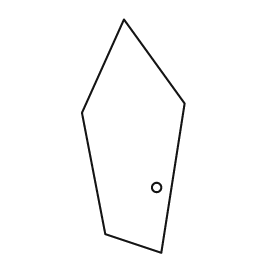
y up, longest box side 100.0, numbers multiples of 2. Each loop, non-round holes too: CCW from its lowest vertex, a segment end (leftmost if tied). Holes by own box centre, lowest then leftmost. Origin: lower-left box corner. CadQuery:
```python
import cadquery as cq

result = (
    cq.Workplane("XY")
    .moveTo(34.0, 0.0)
    .lineTo(44.0, 64.0)
    .lineTo(18.0, 100.0)
    .lineTo(0.0, 60.0)
    .lineTo(10.0, 8.0)
    .close()
    .moveTo(32.0, 28.0)
    .circle(2.0)
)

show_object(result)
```